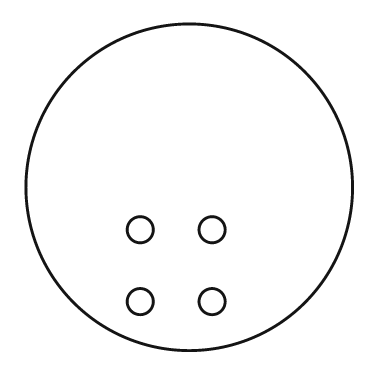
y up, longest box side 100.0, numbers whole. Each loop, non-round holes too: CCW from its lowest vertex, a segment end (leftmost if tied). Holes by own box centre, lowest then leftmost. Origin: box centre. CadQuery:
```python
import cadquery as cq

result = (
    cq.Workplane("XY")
    .moveTo(0.0, 0.0)
    .circle(50.0)
    .moveTo(-15.0, -35.0)
    .circle(4.0)
    .moveTo(7.0, -35.0)
    .circle(4.0)
    .moveTo(-15.0, -13.0)
    .circle(4.0)
    .moveTo(7.0, -13.0)
    .circle(4.0)
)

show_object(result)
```